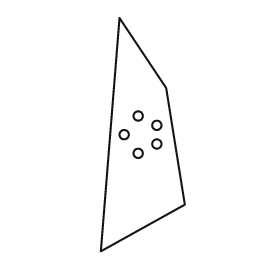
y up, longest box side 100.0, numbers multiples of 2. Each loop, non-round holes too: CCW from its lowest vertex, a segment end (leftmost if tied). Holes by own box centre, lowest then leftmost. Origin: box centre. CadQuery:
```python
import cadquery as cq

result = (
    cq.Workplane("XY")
    .moveTo(-18.0, -50.0)
    .lineTo(18.0, -30.0)
    .lineTo(10.0, 20.0)
    .lineTo(-10.0, 50.0)
    .close()
    .moveTo(-2.0, -8.0)
    .circle(2.0)
    .moveTo(6.0, -4.0)
    .circle(2.0)
    .moveTo(-8.0, 0.0)
    .circle(2.0)
    .moveTo(6.0, 4.0)
    .circle(2.0)
    .moveTo(-2.0, 8.0)
    .circle(2.0)
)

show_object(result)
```